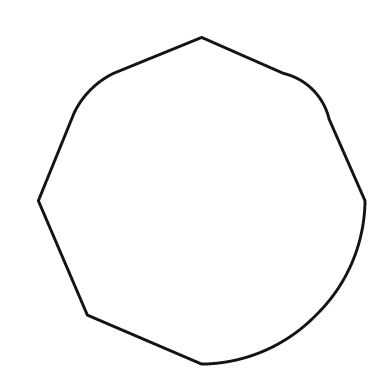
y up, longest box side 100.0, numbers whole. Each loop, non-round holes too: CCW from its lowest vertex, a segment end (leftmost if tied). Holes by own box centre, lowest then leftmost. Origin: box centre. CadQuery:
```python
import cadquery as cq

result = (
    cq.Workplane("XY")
    .moveTo(0.0, -50.0)
    .threePointArc((19.0, -46.0), (35.0, -35.0))
    .threePointArc((46.0, -19.0), (50.0, 0.0))
    .lineTo(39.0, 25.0)
    .threePointArc((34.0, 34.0), (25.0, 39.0))
    .lineTo(0.0, 50.0)
    .lineTo(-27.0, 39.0)
    .threePointArc((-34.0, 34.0), (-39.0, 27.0))
    .lineTo(-50.0, 0.0)
    .lineTo(-35.0, -35.0)
    .close()
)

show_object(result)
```